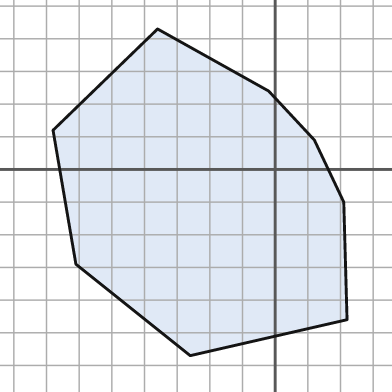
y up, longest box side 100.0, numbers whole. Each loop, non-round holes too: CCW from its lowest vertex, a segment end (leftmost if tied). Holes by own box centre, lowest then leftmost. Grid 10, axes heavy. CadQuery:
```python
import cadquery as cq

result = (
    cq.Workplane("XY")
    .moveTo(-26.0, -57.0)
    .lineTo(22.0, -46.0)
    .lineTo(21.0, -10.0)
    .lineTo(12.0, 9.0)
    .lineTo(-2.0, 24.0)
    .lineTo(-36.0, 43.0)
    .lineTo(-68.0, 12.0)
    .lineTo(-61.0, -29.0)
    .close()
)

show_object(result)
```